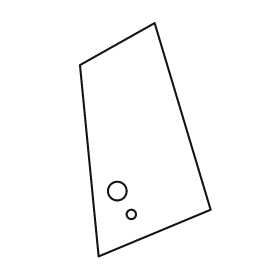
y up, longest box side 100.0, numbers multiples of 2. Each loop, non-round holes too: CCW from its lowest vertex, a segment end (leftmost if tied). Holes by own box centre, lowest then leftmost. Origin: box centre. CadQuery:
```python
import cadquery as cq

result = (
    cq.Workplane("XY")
    .moveTo(-20.0, -50.0)
    .lineTo(28.0, -30.0)
    .lineTo(4.0, 50.0)
    .lineTo(-28.0, 32.0)
    .close()
    .moveTo(-6.0, -32.0)
    .circle(2.0)
    .moveTo(-12.0, -22.0)
    .circle(4.0)
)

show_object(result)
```